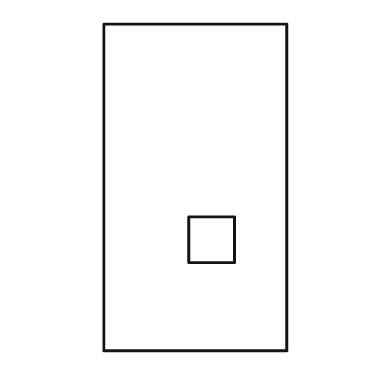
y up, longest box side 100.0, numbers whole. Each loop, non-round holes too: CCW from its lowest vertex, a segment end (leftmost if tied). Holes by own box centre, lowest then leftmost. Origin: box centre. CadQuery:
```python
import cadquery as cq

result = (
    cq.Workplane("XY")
    .moveTo(-28.0, -50.0)
    .lineTo(28.0, -50.0)
    .lineTo(28.0, 50.0)
    .lineTo(-28.0, 50.0)
    .close()
    .moveTo(-2.0, -23.0)
    .lineTo(12.0, -23.0)
    .lineTo(12.0, -9.0)
    .lineTo(-2.0, -9.0)
    .close()
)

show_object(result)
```